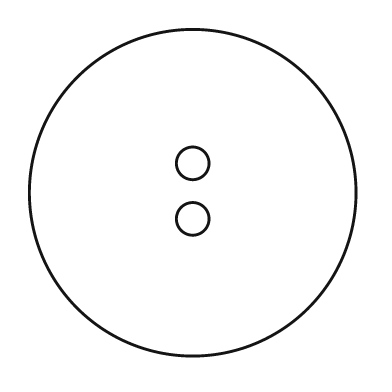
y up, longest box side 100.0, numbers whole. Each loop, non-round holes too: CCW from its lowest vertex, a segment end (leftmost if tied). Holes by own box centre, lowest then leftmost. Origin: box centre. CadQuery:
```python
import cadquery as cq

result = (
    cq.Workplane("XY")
    .moveTo(0.0, 0.0)
    .circle(50.0)
    .moveTo(0.0, -8.0)
    .circle(5.0)
    .moveTo(0.0, 9.0)
    .circle(5.0)
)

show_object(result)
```